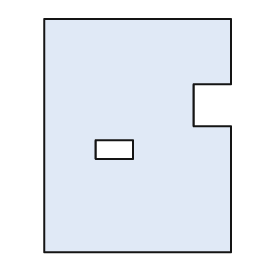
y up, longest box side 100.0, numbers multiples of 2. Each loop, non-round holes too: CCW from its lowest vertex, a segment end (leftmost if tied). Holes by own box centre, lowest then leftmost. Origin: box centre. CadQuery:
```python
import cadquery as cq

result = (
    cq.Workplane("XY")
    .moveTo(-40.0, -50.0)
    .lineTo(40.0, -50.0)
    .lineTo(40.0, 4.0)
    .lineTo(24.0, 4.0)
    .lineTo(24.0, 22.0)
    .lineTo(40.0, 22.0)
    .lineTo(40.0, 50.0)
    .lineTo(-40.0, 50.0)
    .close()
    .moveTo(-18.0, -10.0)
    .lineTo(-2.0, -10.0)
    .lineTo(-2.0, -2.0)
    .lineTo(-18.0, -2.0)
    .close()
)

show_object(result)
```